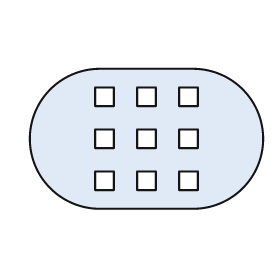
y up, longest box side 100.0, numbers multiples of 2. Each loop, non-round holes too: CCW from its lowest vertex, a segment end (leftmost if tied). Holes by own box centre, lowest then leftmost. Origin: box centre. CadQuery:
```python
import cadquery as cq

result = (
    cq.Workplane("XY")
    .moveTo(-20.0, -30.0)
    .lineTo(20.0, -30.0)
    .threePointArc((50.0, 0.0), (20.0, 30.0))
    .lineTo(-20.0, 30.0)
    .threePointArc((-50.0, 0.0), (-20.0, -30.0))
    .close()
    .moveTo(-22.0, -22.0)
    .lineTo(-14.0, -22.0)
    .lineTo(-14.0, -14.0)
    .lineTo(-22.0, -14.0)
    .close()
    .moveTo(-4.0, -22.0)
    .lineTo(4.0, -22.0)
    .lineTo(4.0, -14.0)
    .lineTo(-4.0, -14.0)
    .close()
    .moveTo(14.0, -22.0)
    .lineTo(22.0, -22.0)
    .lineTo(22.0, -14.0)
    .lineTo(14.0, -14.0)
    .close()
    .moveTo(-22.0, -4.0)
    .lineTo(-14.0, -4.0)
    .lineTo(-14.0, 4.0)
    .lineTo(-22.0, 4.0)
    .close()
    .moveTo(-4.0, -4.0)
    .lineTo(4.0, -4.0)
    .lineTo(4.0, 4.0)
    .lineTo(-4.0, 4.0)
    .close()
    .moveTo(14.0, -4.0)
    .lineTo(22.0, -4.0)
    .lineTo(22.0, 4.0)
    .lineTo(14.0, 4.0)
    .close()
    .moveTo(-22.0, 14.0)
    .lineTo(-14.0, 14.0)
    .lineTo(-14.0, 22.0)
    .lineTo(-22.0, 22.0)
    .close()
    .moveTo(-4.0, 14.0)
    .lineTo(4.0, 14.0)
    .lineTo(4.0, 22.0)
    .lineTo(-4.0, 22.0)
    .close()
    .moveTo(14.0, 14.0)
    .lineTo(22.0, 14.0)
    .lineTo(22.0, 22.0)
    .lineTo(14.0, 22.0)
    .close()
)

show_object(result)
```